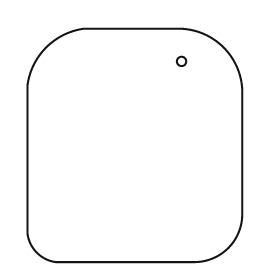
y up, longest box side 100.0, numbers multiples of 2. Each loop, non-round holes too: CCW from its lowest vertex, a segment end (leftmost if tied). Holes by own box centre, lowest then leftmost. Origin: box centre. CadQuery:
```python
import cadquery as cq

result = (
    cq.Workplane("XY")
    .moveTo(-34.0, -50.0)
    .lineTo(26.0, -50.0)
    .threePointArc((40.0, -44.0), (46.0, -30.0))
    .lineTo(46.0, 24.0)
    .threePointArc((38.0, 42.0), (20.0, 50.0))
    .lineTo(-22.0, 50.0)
    .threePointArc((-38.0, 42.0), (-46.0, 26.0))
    .lineTo(-46.0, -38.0)
    .threePointArc((-42.0, -46.0), (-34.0, -50.0))
    .close()
    .moveTo(20.0, 36.0)
    .circle(2.0)
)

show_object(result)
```